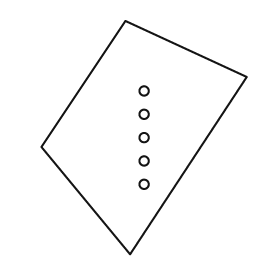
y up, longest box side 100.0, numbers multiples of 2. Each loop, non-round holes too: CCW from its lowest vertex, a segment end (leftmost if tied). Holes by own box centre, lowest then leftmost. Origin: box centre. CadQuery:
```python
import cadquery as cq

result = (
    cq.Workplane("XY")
    .moveTo(-6.0, -50.0)
    .lineTo(44.0, 26.0)
    .lineTo(-8.0, 50.0)
    .lineTo(-44.0, -4.0)
    .close()
    .moveTo(0.0, -20.0)
    .circle(2.0)
    .moveTo(0.0, -10.0)
    .circle(2.0)
    .moveTo(0.0, 0.0)
    .circle(2.0)
    .moveTo(0.0, 10.0)
    .circle(2.0)
    .moveTo(0.0, 20.0)
    .circle(2.0)
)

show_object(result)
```